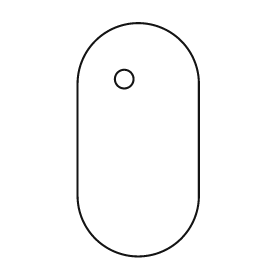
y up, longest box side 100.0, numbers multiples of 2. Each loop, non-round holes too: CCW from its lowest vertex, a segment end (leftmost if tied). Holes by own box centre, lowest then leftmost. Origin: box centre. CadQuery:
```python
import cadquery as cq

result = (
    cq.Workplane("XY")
    .moveTo(-26.0, -24.0)
    .threePointArc((0.0, -50.0), (26.0, -24.0))
    .lineTo(26.0, 24.0)
    .threePointArc((0.0, 50.0), (-26.0, 24.0))
    .close()
    .moveTo(-6.0, 26.0)
    .circle(4.0)
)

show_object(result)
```